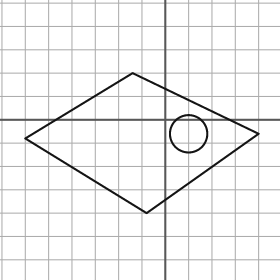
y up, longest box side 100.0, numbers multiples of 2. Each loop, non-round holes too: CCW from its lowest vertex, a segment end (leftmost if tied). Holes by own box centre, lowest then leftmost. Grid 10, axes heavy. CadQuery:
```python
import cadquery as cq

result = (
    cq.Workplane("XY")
    .moveTo(-8.0, -40.0)
    .lineTo(40.0, -6.0)
    .lineTo(-14.0, 20.0)
    .lineTo(-60.0, -8.0)
    .close()
    .moveTo(10.0, -6.0)
    .circle(8.0)
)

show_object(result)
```